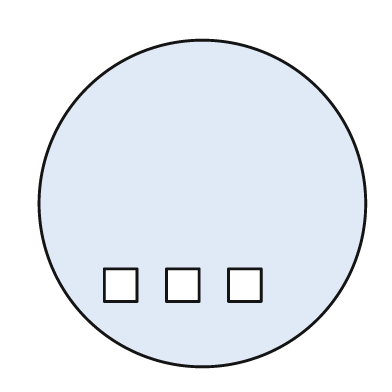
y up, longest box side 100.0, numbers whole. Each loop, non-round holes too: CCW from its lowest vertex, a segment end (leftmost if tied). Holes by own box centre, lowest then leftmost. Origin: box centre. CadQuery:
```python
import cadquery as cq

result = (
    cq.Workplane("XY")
    .moveTo(0.0, 0.0)
    .circle(50.0)
    .moveTo(-30.0, -30.0)
    .lineTo(-20.0, -30.0)
    .lineTo(-20.0, -20.0)
    .lineTo(-30.0, -20.0)
    .close()
    .moveTo(-11.0, -30.0)
    .lineTo(-1.0, -30.0)
    .lineTo(-1.0, -20.0)
    .lineTo(-11.0, -20.0)
    .close()
    .moveTo(8.0, -30.0)
    .lineTo(18.0, -30.0)
    .lineTo(18.0, -20.0)
    .lineTo(8.0, -20.0)
    .close()
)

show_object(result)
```